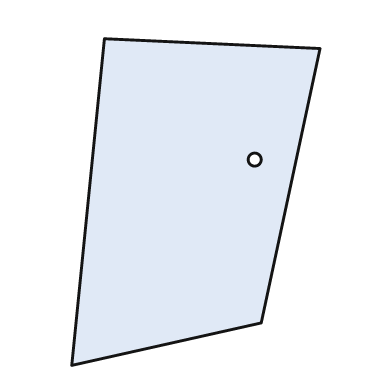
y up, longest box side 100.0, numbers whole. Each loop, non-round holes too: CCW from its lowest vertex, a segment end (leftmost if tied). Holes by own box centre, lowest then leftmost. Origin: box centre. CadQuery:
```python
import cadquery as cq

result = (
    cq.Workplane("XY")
    .moveTo(-38.0, -50.0)
    .lineTo(20.0, -37.0)
    .lineTo(38.0, 47.0)
    .lineTo(-28.0, 50.0)
    .close()
    .moveTo(18.0, 13.0)
    .circle(2.0)
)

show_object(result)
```